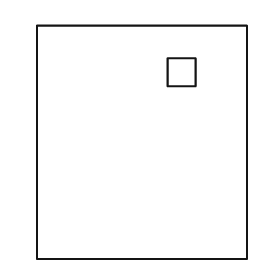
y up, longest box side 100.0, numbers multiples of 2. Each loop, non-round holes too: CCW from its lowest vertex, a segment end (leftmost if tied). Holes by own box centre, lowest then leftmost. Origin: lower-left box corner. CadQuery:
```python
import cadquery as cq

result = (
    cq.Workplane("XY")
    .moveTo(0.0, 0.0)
    .lineTo(90.0, 0.0)
    .lineTo(90.0, 100.0)
    .lineTo(0.0, 100.0)
    .close()
    .moveTo(56.0, 74.0)
    .lineTo(68.0, 74.0)
    .lineTo(68.0, 86.0)
    .lineTo(56.0, 86.0)
    .close()
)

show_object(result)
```